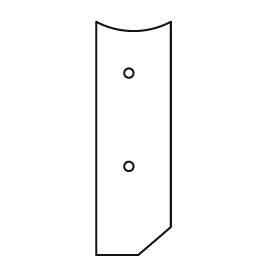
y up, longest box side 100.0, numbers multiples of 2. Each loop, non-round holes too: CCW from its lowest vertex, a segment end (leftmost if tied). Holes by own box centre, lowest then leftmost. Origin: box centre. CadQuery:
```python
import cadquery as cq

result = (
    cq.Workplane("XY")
    .moveTo(-16.0, -50.0)
    .lineTo(2.0, -50.0)
    .lineTo(16.0, -38.0)
    .lineTo(16.0, 50.0)
    .threePointArc((0.0, 46.0), (-16.0, 50.0))
    .close()
    .moveTo(-2.0, -12.0)
    .circle(2.0)
    .moveTo(-2.0, 28.0)
    .circle(2.0)
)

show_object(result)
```